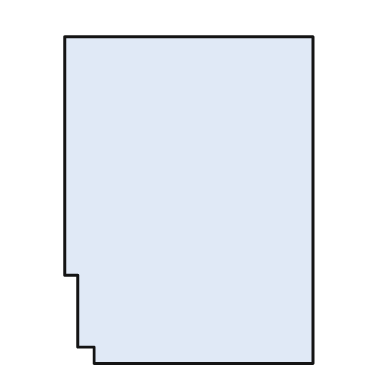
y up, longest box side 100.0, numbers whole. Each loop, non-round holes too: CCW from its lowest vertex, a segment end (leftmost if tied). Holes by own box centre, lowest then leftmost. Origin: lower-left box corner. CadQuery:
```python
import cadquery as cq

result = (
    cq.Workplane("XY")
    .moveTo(9.0, 0.0)
    .lineTo(76.0, 0.0)
    .lineTo(76.0, 100.0)
    .lineTo(0.0, 100.0)
    .lineTo(0.0, 27.0)
    .lineTo(4.0, 27.0)
    .lineTo(4.0, 5.0)
    .lineTo(9.0, 5.0)
    .close()
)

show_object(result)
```